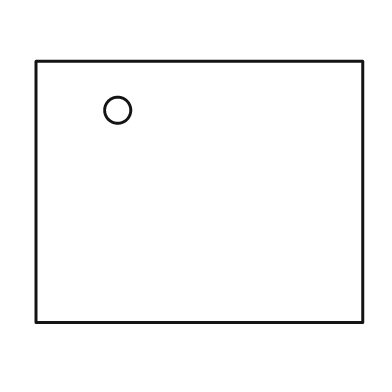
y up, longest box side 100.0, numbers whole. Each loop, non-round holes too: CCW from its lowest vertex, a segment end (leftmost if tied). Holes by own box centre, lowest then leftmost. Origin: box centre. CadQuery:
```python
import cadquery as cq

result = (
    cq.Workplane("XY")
    .moveTo(-50.0, -40.0)
    .lineTo(50.0, -40.0)
    .lineTo(50.0, 40.0)
    .lineTo(-50.0, 40.0)
    .close()
    .moveTo(-25.0, 25.0)
    .circle(4.0)
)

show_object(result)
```